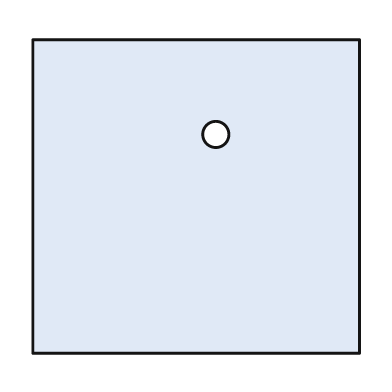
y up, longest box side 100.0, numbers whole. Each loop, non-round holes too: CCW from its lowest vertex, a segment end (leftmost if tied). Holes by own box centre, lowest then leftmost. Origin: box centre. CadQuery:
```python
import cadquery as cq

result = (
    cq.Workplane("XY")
    .moveTo(-50.0, -48.0)
    .lineTo(50.0, -48.0)
    .lineTo(50.0, 48.0)
    .lineTo(-50.0, 48.0)
    .close()
    .moveTo(6.0, 19.0)
    .circle(4.0)
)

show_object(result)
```